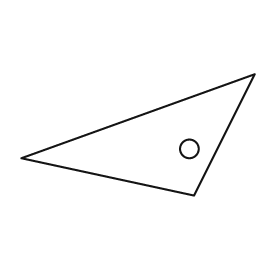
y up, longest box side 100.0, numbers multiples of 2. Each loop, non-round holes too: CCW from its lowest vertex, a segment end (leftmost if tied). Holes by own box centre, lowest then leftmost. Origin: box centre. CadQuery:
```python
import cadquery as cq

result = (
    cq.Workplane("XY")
    .moveTo(24.0, -26.0)
    .lineTo(50.0, 26.0)
    .lineTo(-50.0, -10.0)
    .close()
    .moveTo(22.0, -6.0)
    .circle(4.0)
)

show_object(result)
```